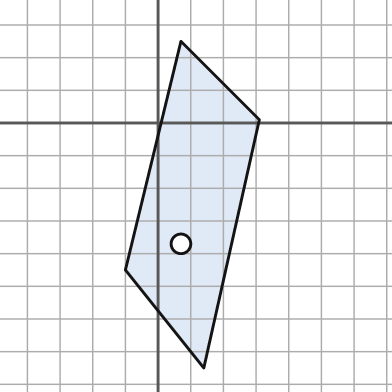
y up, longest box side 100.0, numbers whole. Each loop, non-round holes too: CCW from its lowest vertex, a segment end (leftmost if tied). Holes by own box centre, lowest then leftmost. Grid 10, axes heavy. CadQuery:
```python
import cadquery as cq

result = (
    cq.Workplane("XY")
    .moveTo(14.0, -75.0)
    .lineTo(31.0, 1.0)
    .lineTo(7.0, 25.0)
    .lineTo(-10.0, -45.0)
    .close()
    .moveTo(7.0, -37.0)
    .circle(3.0)
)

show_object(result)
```